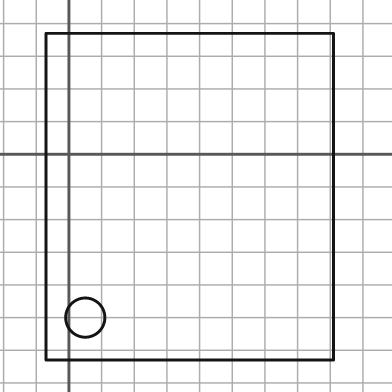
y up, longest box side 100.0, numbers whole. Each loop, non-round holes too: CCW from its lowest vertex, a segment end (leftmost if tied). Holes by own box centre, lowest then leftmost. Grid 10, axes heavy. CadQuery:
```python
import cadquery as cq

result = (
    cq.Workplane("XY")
    .moveTo(-7.0, -63.0)
    .lineTo(81.0, -63.0)
    .lineTo(81.0, 37.0)
    .lineTo(-7.0, 37.0)
    .close()
    .moveTo(5.0, -50.0)
    .circle(6.0)
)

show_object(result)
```